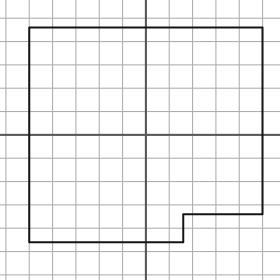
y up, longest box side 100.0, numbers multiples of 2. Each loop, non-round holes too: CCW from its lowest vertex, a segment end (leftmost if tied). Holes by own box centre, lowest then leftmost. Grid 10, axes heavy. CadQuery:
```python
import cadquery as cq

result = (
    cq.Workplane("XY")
    .moveTo(-50.0, -46.0)
    .lineTo(16.0, -46.0)
    .lineTo(16.0, -34.0)
    .lineTo(50.0, -34.0)
    .lineTo(50.0, 46.0)
    .lineTo(-50.0, 46.0)
    .close()
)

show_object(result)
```